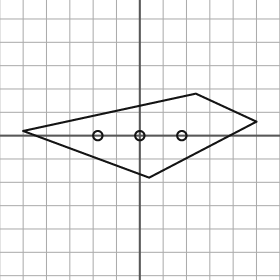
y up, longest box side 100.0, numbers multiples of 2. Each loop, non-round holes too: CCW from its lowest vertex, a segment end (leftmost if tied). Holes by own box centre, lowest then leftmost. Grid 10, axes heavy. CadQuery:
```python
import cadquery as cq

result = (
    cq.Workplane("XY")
    .moveTo(4.0, -18.0)
    .lineTo(50.0, 6.0)
    .lineTo(24.0, 18.0)
    .lineTo(-50.0, 2.0)
    .close()
    .moveTo(-18.0, 0.0)
    .circle(2.0)
    .moveTo(0.0, 0.0)
    .circle(2.0)
    .moveTo(18.0, 0.0)
    .circle(2.0)
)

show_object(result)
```